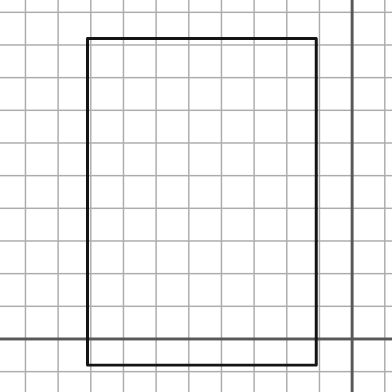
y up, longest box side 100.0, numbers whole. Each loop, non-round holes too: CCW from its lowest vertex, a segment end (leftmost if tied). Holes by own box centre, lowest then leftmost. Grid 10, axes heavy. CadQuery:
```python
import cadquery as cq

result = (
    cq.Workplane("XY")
    .moveTo(-81.0, -8.0)
    .lineTo(-11.0, -8.0)
    .lineTo(-11.0, 92.0)
    .lineTo(-81.0, 92.0)
    .close()
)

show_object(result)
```